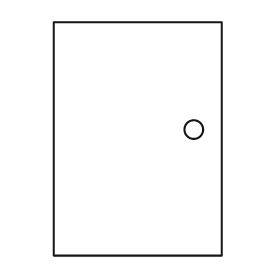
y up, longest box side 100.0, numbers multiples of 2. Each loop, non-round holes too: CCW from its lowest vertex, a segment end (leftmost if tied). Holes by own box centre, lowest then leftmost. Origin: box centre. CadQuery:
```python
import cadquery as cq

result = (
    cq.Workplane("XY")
    .moveTo(-36.0, -50.0)
    .lineTo(36.0, -50.0)
    .lineTo(36.0, 50.0)
    .lineTo(-36.0, 50.0)
    .close()
    .moveTo(24.0, 4.0)
    .circle(4.0)
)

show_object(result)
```